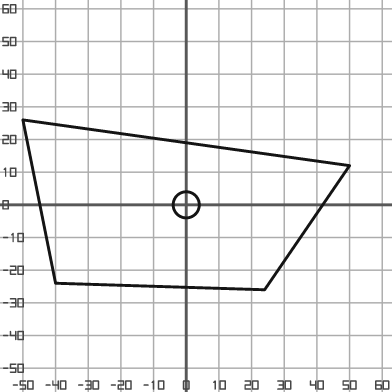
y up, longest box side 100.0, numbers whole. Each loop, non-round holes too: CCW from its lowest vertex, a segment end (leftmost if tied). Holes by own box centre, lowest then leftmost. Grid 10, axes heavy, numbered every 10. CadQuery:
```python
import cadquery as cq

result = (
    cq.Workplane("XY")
    .moveTo(24.0, -26.0)
    .lineTo(50.0, 12.0)
    .lineTo(-50.0, 26.0)
    .lineTo(-40.0, -24.0)
    .close()
    .moveTo(0.0, 0.0)
    .circle(4.0)
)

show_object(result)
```